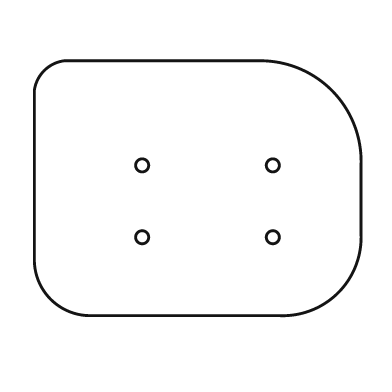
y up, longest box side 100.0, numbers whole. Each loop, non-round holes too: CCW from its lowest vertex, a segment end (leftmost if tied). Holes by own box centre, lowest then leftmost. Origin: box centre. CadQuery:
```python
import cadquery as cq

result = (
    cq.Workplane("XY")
    .moveTo(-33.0, -39.0)
    .lineTo(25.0, -39.0)
    .threePointArc((43.0, -32.0), (50.0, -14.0))
    .lineTo(50.0, 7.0)
    .threePointArc((41.0, 30.0), (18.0, 39.0))
    .lineTo(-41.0, 39.0)
    .threePointArc((-47.0, 36.0), (-50.0, 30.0))
    .lineTo(-50.0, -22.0)
    .threePointArc((-45.0, -34.0), (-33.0, -39.0))
    .close()
    .moveTo(-17.0, -15.0)
    .circle(2.0)
    .moveTo(23.0, -15.0)
    .circle(2.0)
    .moveTo(-17.0, 7.0)
    .circle(2.0)
    .moveTo(23.0, 7.0)
    .circle(2.0)
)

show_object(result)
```